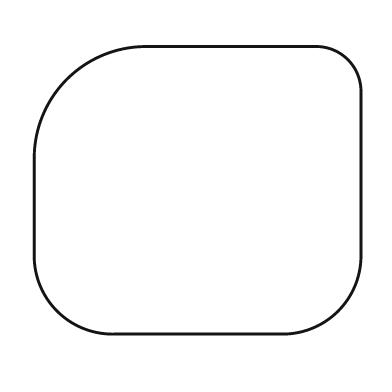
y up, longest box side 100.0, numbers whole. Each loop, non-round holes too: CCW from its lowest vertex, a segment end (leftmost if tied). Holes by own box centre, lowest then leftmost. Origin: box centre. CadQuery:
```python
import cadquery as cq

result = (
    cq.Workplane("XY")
    .moveTo(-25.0, -44.0)
    .lineTo(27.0, -44.0)
    .threePointArc((43.0, -37.0), (50.0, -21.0))
    .lineTo(50.0, 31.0)
    .threePointArc((46.0, 40.0), (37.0, 44.0))
    .lineTo(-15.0, 44.0)
    .threePointArc((-40.0, 34.0), (-50.0, 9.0))
    .lineTo(-50.0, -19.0)
    .threePointArc((-43.0, -37.0), (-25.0, -44.0))
    .close()
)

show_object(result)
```